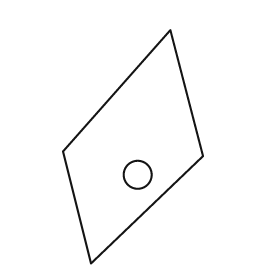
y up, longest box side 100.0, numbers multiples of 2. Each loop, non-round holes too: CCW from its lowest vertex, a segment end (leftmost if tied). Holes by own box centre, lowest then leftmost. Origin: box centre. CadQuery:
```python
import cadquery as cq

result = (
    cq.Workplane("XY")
    .moveTo(-18.0, -50.0)
    .lineTo(30.0, -4.0)
    .lineTo(16.0, 50.0)
    .lineTo(-30.0, -2.0)
    .close()
    .moveTo(2.0, -12.0)
    .circle(6.0)
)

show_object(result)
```